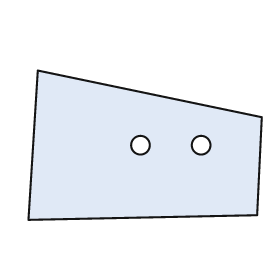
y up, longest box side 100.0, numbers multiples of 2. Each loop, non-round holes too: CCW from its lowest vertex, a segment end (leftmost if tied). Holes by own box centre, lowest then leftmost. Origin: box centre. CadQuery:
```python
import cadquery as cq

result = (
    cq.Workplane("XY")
    .moveTo(-50.0, -32.0)
    .lineTo(48.0, -30.0)
    .lineTo(50.0, 12.0)
    .lineTo(-46.0, 32.0)
    .close()
    .moveTo(-2.0, 0.0)
    .circle(4.0)
    .moveTo(24.0, 0.0)
    .circle(4.0)
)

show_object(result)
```